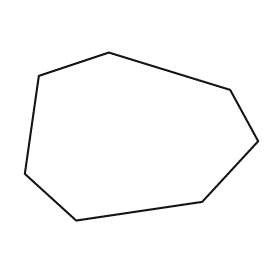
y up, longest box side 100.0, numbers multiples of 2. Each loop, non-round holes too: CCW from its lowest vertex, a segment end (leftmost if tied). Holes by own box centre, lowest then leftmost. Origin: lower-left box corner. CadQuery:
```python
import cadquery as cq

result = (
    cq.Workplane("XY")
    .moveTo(22.0, 0.0)
    .lineTo(76.0, 8.0)
    .lineTo(100.0, 34.0)
    .lineTo(88.0, 56.0)
    .lineTo(36.0, 72.0)
    .lineTo(6.0, 62.0)
    .lineTo(0.0, 20.0)
    .close()
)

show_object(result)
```